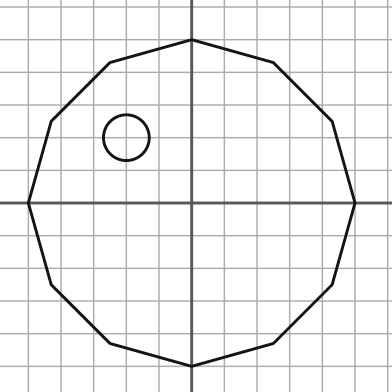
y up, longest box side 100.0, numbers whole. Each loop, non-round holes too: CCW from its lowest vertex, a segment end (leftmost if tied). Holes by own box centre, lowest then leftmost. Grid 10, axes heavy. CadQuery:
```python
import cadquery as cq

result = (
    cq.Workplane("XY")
    .moveTo(0.0, -50.0)
    .lineTo(25.0, -43.0)
    .lineTo(43.0, -25.0)
    .lineTo(50.0, 0.0)
    .lineTo(43.0, 25.0)
    .lineTo(25.0, 43.0)
    .lineTo(0.0, 50.0)
    .lineTo(-25.0, 43.0)
    .lineTo(-43.0, 25.0)
    .lineTo(-50.0, 0.0)
    .lineTo(-43.0, -25.0)
    .lineTo(-25.0, -43.0)
    .close()
    .moveTo(-20.0, 20.0)
    .circle(7.0)
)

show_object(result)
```